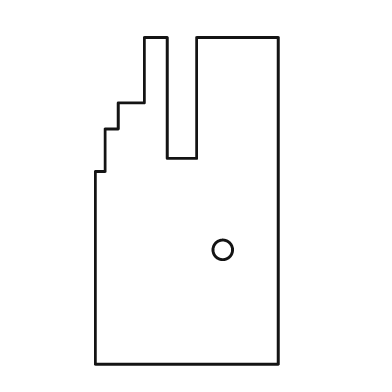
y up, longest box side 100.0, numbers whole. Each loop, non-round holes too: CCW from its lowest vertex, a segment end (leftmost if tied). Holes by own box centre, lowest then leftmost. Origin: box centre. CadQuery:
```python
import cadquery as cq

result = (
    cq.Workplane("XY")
    .moveTo(-28.0, -50.0)
    .lineTo(28.0, -50.0)
    .lineTo(28.0, 50.0)
    .lineTo(3.0, 50.0)
    .lineTo(3.0, 13.0)
    .lineTo(-6.0, 13.0)
    .lineTo(-6.0, 50.0)
    .lineTo(-13.0, 50.0)
    .lineTo(-13.0, 30.0)
    .lineTo(-21.0, 30.0)
    .lineTo(-21.0, 22.0)
    .lineTo(-25.0, 22.0)
    .lineTo(-25.0, 9.0)
    .lineTo(-28.0, 9.0)
    .close()
    .moveTo(11.0, -15.0)
    .circle(3.0)
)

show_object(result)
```